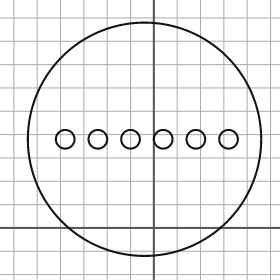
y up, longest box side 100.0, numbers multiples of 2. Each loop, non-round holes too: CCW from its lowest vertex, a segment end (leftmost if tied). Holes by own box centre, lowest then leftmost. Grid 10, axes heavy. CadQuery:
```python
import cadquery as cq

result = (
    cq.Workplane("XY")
    .moveTo(-4.0, 38.0)
    .circle(50.0)
    .moveTo(-38.0, 38.0)
    .circle(4.0)
    .moveTo(-24.0, 38.0)
    .circle(4.0)
    .moveTo(-10.0, 38.0)
    .circle(4.0)
    .moveTo(4.0, 38.0)
    .circle(4.0)
    .moveTo(18.0, 38.0)
    .circle(4.0)
    .moveTo(32.0, 38.0)
    .circle(4.0)
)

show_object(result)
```